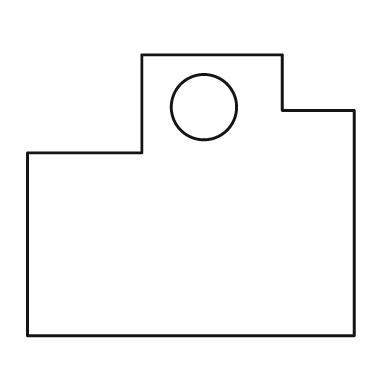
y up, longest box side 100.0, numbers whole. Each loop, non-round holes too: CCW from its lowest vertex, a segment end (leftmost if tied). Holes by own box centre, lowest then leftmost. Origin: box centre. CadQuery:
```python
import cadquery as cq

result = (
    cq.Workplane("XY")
    .moveTo(-50.0, -43.0)
    .lineTo(50.0, -43.0)
    .lineTo(50.0, 26.0)
    .lineTo(28.0, 26.0)
    .lineTo(28.0, 43.0)
    .lineTo(-15.0, 43.0)
    .lineTo(-15.0, 13.0)
    .lineTo(-50.0, 13.0)
    .close()
    .moveTo(4.0, 27.0)
    .circle(10.0)
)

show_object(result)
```